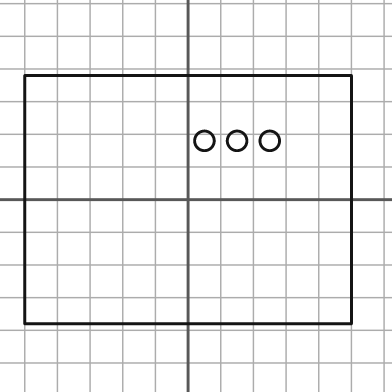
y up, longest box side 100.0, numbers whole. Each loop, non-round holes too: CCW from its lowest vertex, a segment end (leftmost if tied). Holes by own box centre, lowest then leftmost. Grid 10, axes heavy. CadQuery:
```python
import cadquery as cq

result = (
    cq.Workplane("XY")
    .moveTo(-50.0, -38.0)
    .lineTo(50.0, -38.0)
    .lineTo(50.0, 38.0)
    .lineTo(-50.0, 38.0)
    .close()
    .moveTo(5.0, 18.0)
    .circle(3.0)
    .moveTo(15.0, 18.0)
    .circle(3.0)
    .moveTo(25.0, 18.0)
    .circle(3.0)
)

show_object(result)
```